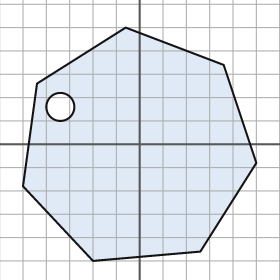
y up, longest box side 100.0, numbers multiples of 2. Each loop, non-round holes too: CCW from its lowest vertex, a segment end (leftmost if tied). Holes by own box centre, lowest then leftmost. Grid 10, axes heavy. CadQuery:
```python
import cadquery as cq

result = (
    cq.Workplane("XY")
    .moveTo(-20.0, -50.0)
    .lineTo(26.0, -46.0)
    .lineTo(50.0, -8.0)
    .lineTo(36.0, 34.0)
    .lineTo(-6.0, 50.0)
    .lineTo(-44.0, 26.0)
    .lineTo(-50.0, -18.0)
    .close()
    .moveTo(-34.0, 16.0)
    .circle(6.0)
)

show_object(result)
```